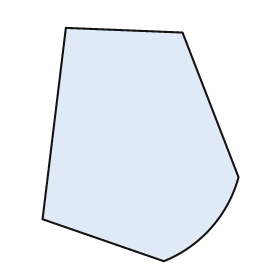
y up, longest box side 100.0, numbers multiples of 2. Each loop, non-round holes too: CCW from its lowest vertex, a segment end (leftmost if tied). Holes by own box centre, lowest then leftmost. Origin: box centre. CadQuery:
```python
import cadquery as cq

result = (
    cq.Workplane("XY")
    .moveTo(10.0, -50.0)
    .threePointArc((30.0, -36.0), (42.0, -14.0))
    .lineTo(18.0, 48.0)
    .lineTo(-32.0, 50.0)
    .lineTo(-42.0, -32.0)
    .close()
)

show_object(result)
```